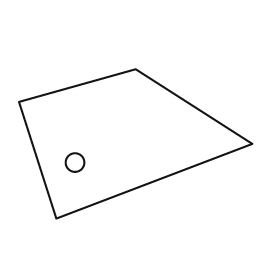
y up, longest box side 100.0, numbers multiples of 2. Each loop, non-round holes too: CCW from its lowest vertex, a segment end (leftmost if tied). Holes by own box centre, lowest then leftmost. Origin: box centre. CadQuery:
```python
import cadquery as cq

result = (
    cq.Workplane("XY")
    .moveTo(-34.0, -32.0)
    .lineTo(50.0, 0.0)
    .lineTo(0.0, 32.0)
    .lineTo(-50.0, 18.0)
    .close()
    .moveTo(-26.0, -8.0)
    .circle(4.0)
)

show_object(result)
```